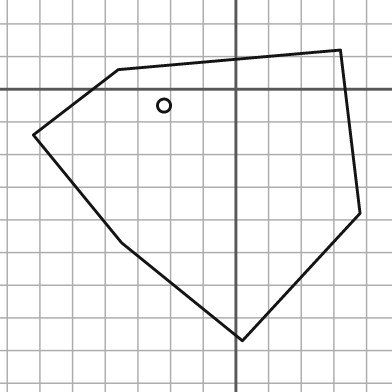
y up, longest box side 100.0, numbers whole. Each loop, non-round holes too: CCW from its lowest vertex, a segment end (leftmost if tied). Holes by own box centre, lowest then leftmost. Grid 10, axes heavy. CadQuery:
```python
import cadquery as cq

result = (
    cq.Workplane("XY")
    .moveTo(2.0, -77.0)
    .lineTo(38.0, -38.0)
    .lineTo(32.0, 12.0)
    .lineTo(-36.0, 6.0)
    .lineTo(-62.0, -14.0)
    .lineTo(-35.0, -47.0)
    .close()
    .moveTo(-22.0, -5.0)
    .circle(2.0)
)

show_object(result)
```